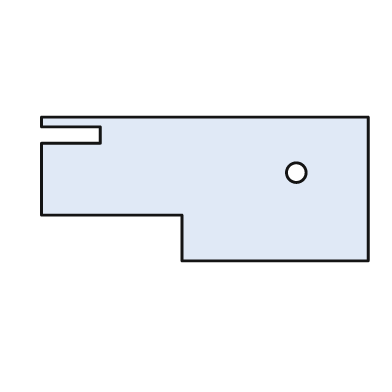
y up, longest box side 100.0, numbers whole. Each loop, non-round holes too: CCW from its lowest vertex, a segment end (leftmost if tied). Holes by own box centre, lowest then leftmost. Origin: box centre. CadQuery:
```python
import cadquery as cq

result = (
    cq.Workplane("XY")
    .moveTo(-7.0, -22.0)
    .lineTo(50.0, -22.0)
    .lineTo(50.0, 22.0)
    .lineTo(-50.0, 22.0)
    .lineTo(-50.0, 19.0)
    .lineTo(-32.0, 19.0)
    .lineTo(-32.0, 14.0)
    .lineTo(-50.0, 14.0)
    .lineTo(-50.0, -8.0)
    .lineTo(-7.0, -8.0)
    .close()
    .moveTo(28.0, 5.0)
    .circle(3.0)
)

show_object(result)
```